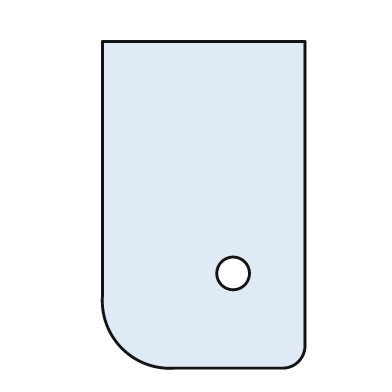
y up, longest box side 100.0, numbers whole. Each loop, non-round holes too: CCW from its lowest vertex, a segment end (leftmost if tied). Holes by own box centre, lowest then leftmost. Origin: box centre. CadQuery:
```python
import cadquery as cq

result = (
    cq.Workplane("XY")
    .moveTo(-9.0, -50.0)
    .lineTo(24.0, -50.0)
    .threePointArc((29.0, -48.0), (31.0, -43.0))
    .lineTo(31.0, 50.0)
    .lineTo(-31.0, 50.0)
    .lineTo(-31.0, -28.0)
    .threePointArc((-25.0, -44.0), (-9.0, -50.0))
    .close()
    .moveTo(9.0, -21.0)
    .circle(5.0)
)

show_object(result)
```